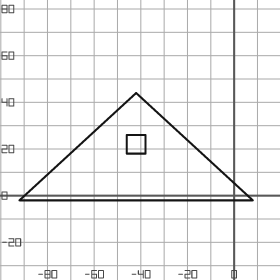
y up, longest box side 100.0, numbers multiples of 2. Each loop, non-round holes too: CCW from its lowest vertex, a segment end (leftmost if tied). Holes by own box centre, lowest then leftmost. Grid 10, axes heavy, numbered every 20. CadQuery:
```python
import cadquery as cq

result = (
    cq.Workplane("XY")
    .moveTo(-92.0, -2.0)
    .lineTo(8.0, -2.0)
    .lineTo(-42.0, 44.0)
    .close()
    .moveTo(-46.0, 18.0)
    .lineTo(-38.0, 18.0)
    .lineTo(-38.0, 26.0)
    .lineTo(-46.0, 26.0)
    .close()
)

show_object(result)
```